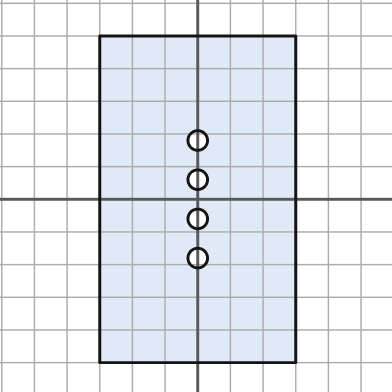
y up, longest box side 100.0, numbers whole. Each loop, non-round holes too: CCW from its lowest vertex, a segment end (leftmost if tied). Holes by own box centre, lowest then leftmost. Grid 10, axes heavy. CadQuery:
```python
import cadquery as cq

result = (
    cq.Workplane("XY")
    .moveTo(-30.0, -50.0)
    .lineTo(30.0, -50.0)
    .lineTo(30.0, 50.0)
    .lineTo(-30.0, 50.0)
    .close()
    .moveTo(0.0, -18.0)
    .circle(3.0)
    .moveTo(0.0, -6.0)
    .circle(3.0)
    .moveTo(0.0, 6.0)
    .circle(3.0)
    .moveTo(0.0, 18.0)
    .circle(3.0)
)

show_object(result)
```